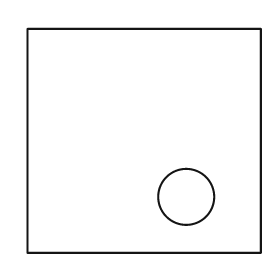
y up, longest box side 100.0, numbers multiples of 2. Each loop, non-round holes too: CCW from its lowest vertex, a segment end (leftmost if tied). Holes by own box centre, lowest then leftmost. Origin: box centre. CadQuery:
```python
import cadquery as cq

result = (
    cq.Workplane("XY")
    .moveTo(-50.0, -48.0)
    .lineTo(50.0, -48.0)
    .lineTo(50.0, 48.0)
    .lineTo(-50.0, 48.0)
    .close()
    .moveTo(18.0, -24.0)
    .circle(12.0)
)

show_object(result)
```